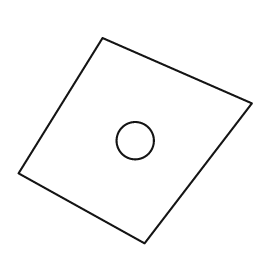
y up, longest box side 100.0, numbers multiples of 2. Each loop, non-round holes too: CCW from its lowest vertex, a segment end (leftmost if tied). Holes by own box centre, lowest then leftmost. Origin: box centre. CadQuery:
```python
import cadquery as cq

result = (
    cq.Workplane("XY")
    .moveTo(4.0, -44.0)
    .lineTo(50.0, 16.0)
    .lineTo(-14.0, 44.0)
    .lineTo(-50.0, -14.0)
    .close()
    .moveTo(0.0, 0.0)
    .circle(8.0)
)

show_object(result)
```